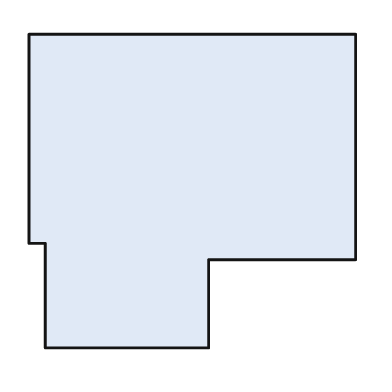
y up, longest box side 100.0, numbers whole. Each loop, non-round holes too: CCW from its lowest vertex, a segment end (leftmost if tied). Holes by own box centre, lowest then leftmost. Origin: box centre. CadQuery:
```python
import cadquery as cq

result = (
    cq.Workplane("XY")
    .moveTo(-45.0, -48.0)
    .lineTo(5.0, -48.0)
    .lineTo(5.0, -21.0)
    .lineTo(50.0, -21.0)
    .lineTo(50.0, 48.0)
    .lineTo(-50.0, 48.0)
    .lineTo(-50.0, -16.0)
    .lineTo(-45.0, -16.0)
    .close()
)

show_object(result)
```